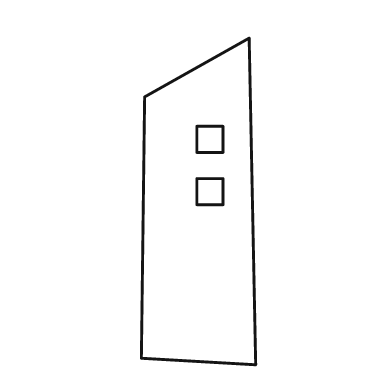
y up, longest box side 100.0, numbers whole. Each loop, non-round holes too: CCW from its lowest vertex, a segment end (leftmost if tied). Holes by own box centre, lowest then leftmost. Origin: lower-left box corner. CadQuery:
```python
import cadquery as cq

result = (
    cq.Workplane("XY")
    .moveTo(35.0, 0.0)
    .lineTo(33.0, 100.0)
    .lineTo(1.0, 82.0)
    .lineTo(0.0, 2.0)
    .close()
    .moveTo(17.0, 49.0)
    .lineTo(25.0, 49.0)
    .lineTo(25.0, 57.0)
    .lineTo(17.0, 57.0)
    .close()
    .moveTo(17.0, 65.0)
    .lineTo(25.0, 65.0)
    .lineTo(25.0, 73.0)
    .lineTo(17.0, 73.0)
    .close()
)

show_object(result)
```